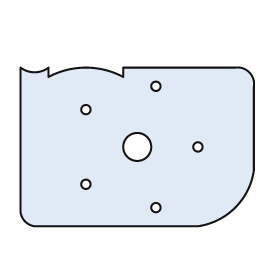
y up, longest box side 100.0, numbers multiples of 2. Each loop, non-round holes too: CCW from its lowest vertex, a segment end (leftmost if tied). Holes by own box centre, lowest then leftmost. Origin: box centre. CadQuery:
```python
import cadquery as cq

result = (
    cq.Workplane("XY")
    .moveTo(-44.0, -34.0)
    .lineTo(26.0, -34.0)
    .threePointArc((42.0, -26.0), (50.0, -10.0))
    .lineTo(50.0, 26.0)
    .threePointArc((48.0, 32.0), (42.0, 34.0))
    .lineTo(-6.0, 34.0)
    .lineTo(-6.0, 30.0)
    .threePointArc((-22.0, 34.0), (-38.0, 30.0))
    .lineTo(-38.0, 34.0)
    .threePointArc((-44.0, 32.0), (-50.0, 34.0))
    .lineTo(-50.0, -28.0)
    .threePointArc((-48.0, -32.0), (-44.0, -34.0))
    .close()
    .moveTo(8.0, -26.0)
    .circle(2.0)
    .moveTo(-22.0, -16.0)
    .circle(2.0)
    .moveTo(0.0, 0.0)
    .circle(6.0)
    .moveTo(26.0, 0.0)
    .circle(2.0)
    .moveTo(-22.0, 16.0)
    .circle(2.0)
    .moveTo(8.0, 26.0)
    .circle(2.0)
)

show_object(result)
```